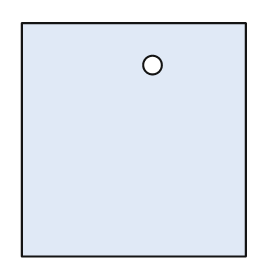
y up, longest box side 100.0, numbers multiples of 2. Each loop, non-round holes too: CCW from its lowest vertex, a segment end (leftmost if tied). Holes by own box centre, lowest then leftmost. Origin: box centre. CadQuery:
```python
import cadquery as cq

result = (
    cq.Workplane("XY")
    .moveTo(-48.0, -50.0)
    .lineTo(48.0, -50.0)
    .lineTo(48.0, 50.0)
    .lineTo(-48.0, 50.0)
    .close()
    .moveTo(8.0, 32.0)
    .circle(4.0)
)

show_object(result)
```